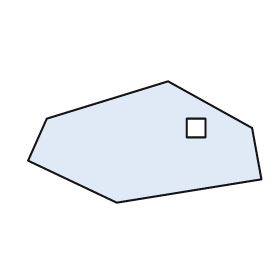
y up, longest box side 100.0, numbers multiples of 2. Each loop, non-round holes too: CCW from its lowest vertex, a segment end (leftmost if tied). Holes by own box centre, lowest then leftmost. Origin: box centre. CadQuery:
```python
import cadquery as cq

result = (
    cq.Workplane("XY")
    .moveTo(-12.0, -26.0)
    .lineTo(50.0, -16.0)
    .lineTo(46.0, 6.0)
    .lineTo(10.0, 26.0)
    .lineTo(-42.0, 10.0)
    .lineTo(-50.0, -8.0)
    .close()
    .moveTo(18.0, 2.0)
    .lineTo(26.0, 2.0)
    .lineTo(26.0, 10.0)
    .lineTo(18.0, 10.0)
    .close()
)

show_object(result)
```